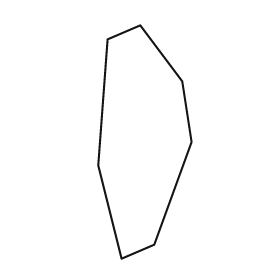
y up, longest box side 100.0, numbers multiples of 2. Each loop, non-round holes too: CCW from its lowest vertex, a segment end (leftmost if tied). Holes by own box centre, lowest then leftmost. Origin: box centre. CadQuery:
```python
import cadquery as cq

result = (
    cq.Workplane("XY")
    .moveTo(-10.0, -50.0)
    .lineTo(4.0, -44.0)
    .lineTo(20.0, 0.0)
    .lineTo(16.0, 26.0)
    .lineTo(-2.0, 50.0)
    .lineTo(-16.0, 44.0)
    .lineTo(-20.0, -10.0)
    .close()
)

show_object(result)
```